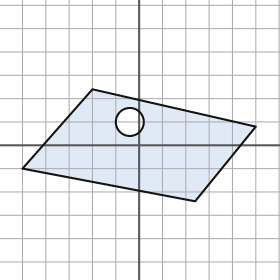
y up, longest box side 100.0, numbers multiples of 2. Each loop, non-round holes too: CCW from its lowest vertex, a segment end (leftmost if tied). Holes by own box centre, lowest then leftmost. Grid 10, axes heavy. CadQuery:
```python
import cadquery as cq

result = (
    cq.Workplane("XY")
    .moveTo(24.0, -24.0)
    .lineTo(50.0, 8.0)
    .lineTo(-20.0, 24.0)
    .lineTo(-50.0, -10.0)
    .close()
    .moveTo(-4.0, 10.0)
    .circle(6.0)
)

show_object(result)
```